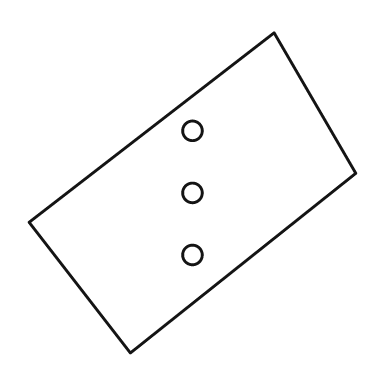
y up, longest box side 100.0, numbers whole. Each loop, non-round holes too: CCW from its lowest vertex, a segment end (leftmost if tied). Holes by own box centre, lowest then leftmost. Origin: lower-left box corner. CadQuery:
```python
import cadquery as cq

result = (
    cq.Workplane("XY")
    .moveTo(31.0, 0.0)
    .lineTo(100.0, 55.0)
    .lineTo(75.0, 98.0)
    .lineTo(0.0, 40.0)
    .close()
    .moveTo(50.0, 30.0)
    .circle(3.0)
    .moveTo(50.0, 49.0)
    .circle(3.0)
    .moveTo(50.0, 68.0)
    .circle(3.0)
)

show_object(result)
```